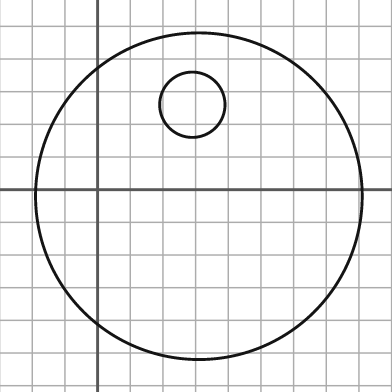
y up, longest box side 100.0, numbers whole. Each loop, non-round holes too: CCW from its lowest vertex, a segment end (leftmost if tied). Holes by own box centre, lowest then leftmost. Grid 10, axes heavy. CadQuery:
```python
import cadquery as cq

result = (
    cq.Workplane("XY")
    .moveTo(31.0, -2.0)
    .circle(50.0)
    .moveTo(29.0, 26.0)
    .circle(10.0)
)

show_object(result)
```